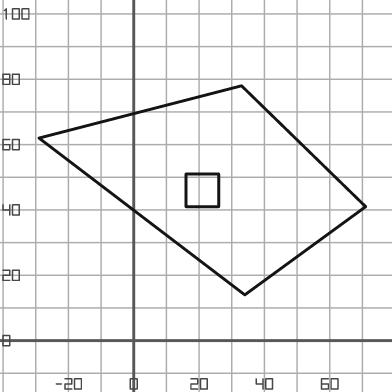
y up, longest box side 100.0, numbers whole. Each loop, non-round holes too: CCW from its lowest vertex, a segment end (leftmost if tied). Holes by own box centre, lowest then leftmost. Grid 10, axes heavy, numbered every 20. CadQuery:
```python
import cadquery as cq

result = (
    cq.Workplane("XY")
    .moveTo(34.0, 14.0)
    .lineTo(71.0, 41.0)
    .lineTo(33.0, 78.0)
    .lineTo(-29.0, 62.0)
    .close()
    .moveTo(16.0, 41.0)
    .lineTo(26.0, 41.0)
    .lineTo(26.0, 51.0)
    .lineTo(16.0, 51.0)
    .close()
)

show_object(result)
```